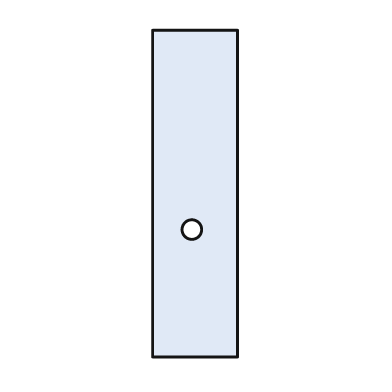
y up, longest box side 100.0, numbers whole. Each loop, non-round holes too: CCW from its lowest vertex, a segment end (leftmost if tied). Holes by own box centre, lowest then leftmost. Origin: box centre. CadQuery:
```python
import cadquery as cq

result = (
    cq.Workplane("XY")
    .moveTo(-13.0, -50.0)
    .lineTo(13.0, -50.0)
    .lineTo(13.0, 50.0)
    .lineTo(-13.0, 50.0)
    .close()
    .moveTo(-1.0, -11.0)
    .circle(3.0)
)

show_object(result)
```